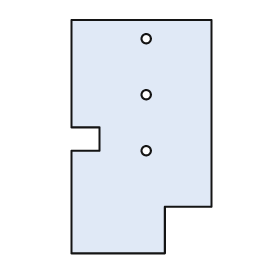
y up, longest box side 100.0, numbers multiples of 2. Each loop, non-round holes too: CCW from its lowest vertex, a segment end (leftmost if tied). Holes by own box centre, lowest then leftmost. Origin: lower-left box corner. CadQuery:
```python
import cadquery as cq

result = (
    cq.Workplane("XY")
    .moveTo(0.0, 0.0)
    .lineTo(40.0, 0.0)
    .lineTo(40.0, 20.0)
    .lineTo(60.0, 20.0)
    .lineTo(60.0, 100.0)
    .lineTo(0.0, 100.0)
    .lineTo(0.0, 54.0)
    .lineTo(12.0, 54.0)
    .lineTo(12.0, 44.0)
    .lineTo(0.0, 44.0)
    .close()
    .moveTo(32.0, 44.0)
    .circle(2.0)
    .moveTo(32.0, 68.0)
    .circle(2.0)
    .moveTo(32.0, 92.0)
    .circle(2.0)
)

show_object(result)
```